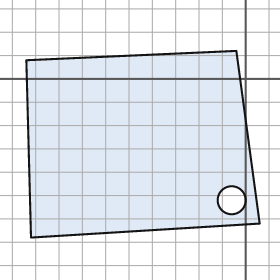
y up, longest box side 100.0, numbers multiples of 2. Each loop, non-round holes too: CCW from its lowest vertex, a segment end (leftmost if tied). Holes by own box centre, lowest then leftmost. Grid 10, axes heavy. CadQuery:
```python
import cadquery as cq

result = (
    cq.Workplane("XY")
    .moveTo(-92.0, -68.0)
    .lineTo(6.0, -62.0)
    .lineTo(-4.0, 12.0)
    .lineTo(-94.0, 8.0)
    .close()
    .moveTo(-6.0, -52.0)
    .circle(6.0)
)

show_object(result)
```